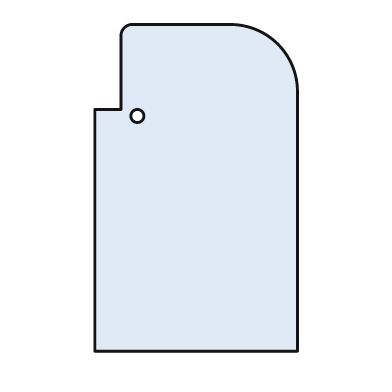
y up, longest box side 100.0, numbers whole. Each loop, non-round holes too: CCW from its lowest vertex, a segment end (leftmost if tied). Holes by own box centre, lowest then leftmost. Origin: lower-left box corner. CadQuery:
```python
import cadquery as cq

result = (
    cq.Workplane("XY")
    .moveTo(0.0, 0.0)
    .lineTo(62.0, 0.0)
    .lineTo(62.0, 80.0)
    .threePointArc((56.0, 94.0), (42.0, 100.0))
    .lineTo(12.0, 100.0)
    .threePointArc((9.0, 99.0), (8.0, 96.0))
    .lineTo(8.0, 74.0)
    .lineTo(0.0, 74.0)
    .close()
    .moveTo(13.0, 72.0)
    .circle(2.0)
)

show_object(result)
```